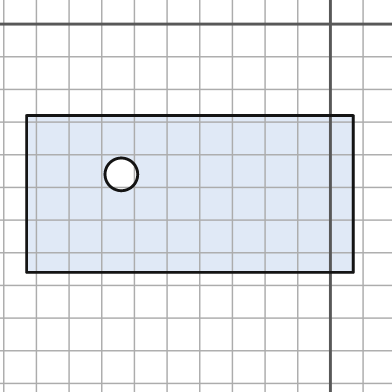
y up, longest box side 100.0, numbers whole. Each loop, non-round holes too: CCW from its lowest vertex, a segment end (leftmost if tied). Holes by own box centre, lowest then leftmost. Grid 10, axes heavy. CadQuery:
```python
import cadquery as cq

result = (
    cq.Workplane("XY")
    .moveTo(-93.0, -76.0)
    .lineTo(7.0, -76.0)
    .lineTo(7.0, -28.0)
    .lineTo(-93.0, -28.0)
    .close()
    .moveTo(-64.0, -46.0)
    .circle(5.0)
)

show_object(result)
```